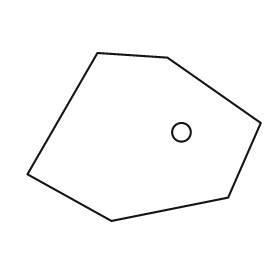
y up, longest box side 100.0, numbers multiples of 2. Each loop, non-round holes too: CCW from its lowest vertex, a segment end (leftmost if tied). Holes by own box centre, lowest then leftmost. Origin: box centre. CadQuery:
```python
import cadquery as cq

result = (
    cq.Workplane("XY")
    .moveTo(-14.0, -36.0)
    .lineTo(36.0, -26.0)
    .lineTo(50.0, 6.0)
    .lineTo(10.0, 34.0)
    .lineTo(-20.0, 36.0)
    .lineTo(-50.0, -16.0)
    .close()
    .moveTo(16.0, 2.0)
    .circle(4.0)
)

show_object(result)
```